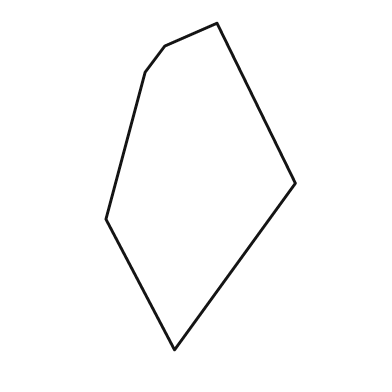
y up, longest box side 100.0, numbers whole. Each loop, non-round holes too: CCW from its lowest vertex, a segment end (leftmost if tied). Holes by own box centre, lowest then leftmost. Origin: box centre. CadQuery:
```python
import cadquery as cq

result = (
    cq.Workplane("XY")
    .moveTo(-8.0, -50.0)
    .lineTo(29.0, 1.0)
    .lineTo(5.0, 50.0)
    .lineTo(-11.0, 43.0)
    .lineTo(-17.0, 35.0)
    .lineTo(-29.0, -10.0)
    .close()
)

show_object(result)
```